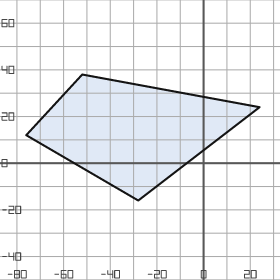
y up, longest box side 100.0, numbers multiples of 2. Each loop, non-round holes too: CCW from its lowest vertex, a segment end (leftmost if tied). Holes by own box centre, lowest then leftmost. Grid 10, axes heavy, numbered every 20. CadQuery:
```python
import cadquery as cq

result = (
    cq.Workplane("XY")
    .moveTo(-28.0, -16.0)
    .lineTo(24.0, 24.0)
    .lineTo(-52.0, 38.0)
    .lineTo(-76.0, 12.0)
    .close()
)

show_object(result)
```